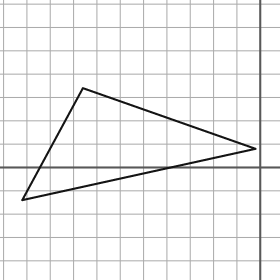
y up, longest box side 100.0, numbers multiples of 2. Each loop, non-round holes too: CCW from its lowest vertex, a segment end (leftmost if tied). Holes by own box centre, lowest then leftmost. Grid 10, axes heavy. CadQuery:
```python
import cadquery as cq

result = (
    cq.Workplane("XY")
    .moveTo(-102.0, -14.0)
    .lineTo(-2.0, 8.0)
    .lineTo(-76.0, 34.0)
    .close()
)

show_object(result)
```